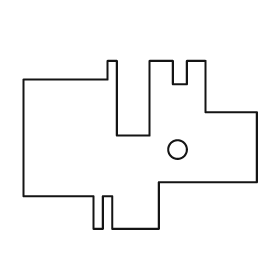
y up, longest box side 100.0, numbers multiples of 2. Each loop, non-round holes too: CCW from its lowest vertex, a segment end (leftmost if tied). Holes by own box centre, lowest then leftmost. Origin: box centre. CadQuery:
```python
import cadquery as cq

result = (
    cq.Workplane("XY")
    .moveTo(-20.0, -36.0)
    .lineTo(-16.0, -36.0)
    .lineTo(-16.0, -22.0)
    .lineTo(-12.0, -22.0)
    .lineTo(-12.0, -36.0)
    .lineTo(8.0, -36.0)
    .lineTo(8.0, -16.0)
    .lineTo(50.0, -16.0)
    .lineTo(50.0, 14.0)
    .lineTo(28.0, 14.0)
    .lineTo(28.0, 36.0)
    .lineTo(20.0, 36.0)
    .lineTo(20.0, 26.0)
    .lineTo(14.0, 26.0)
    .lineTo(14.0, 36.0)
    .lineTo(4.0, 36.0)
    .lineTo(4.0, 4.0)
    .lineTo(-10.0, 4.0)
    .lineTo(-10.0, 36.0)
    .lineTo(-14.0, 36.0)
    .lineTo(-14.0, 28.0)
    .lineTo(-50.0, 28.0)
    .lineTo(-50.0, -22.0)
    .lineTo(-20.0, -22.0)
    .close()
    .moveTo(16.0, -2.0)
    .circle(4.0)
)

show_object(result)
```